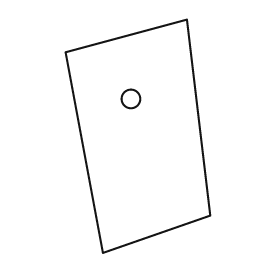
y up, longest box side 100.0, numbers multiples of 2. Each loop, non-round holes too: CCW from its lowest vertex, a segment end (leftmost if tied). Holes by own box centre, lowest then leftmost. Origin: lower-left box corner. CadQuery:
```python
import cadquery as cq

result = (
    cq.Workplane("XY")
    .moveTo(16.0, 0.0)
    .lineTo(62.0, 16.0)
    .lineTo(52.0, 100.0)
    .lineTo(0.0, 86.0)
    .close()
    .moveTo(28.0, 66.0)
    .circle(4.0)
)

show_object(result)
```